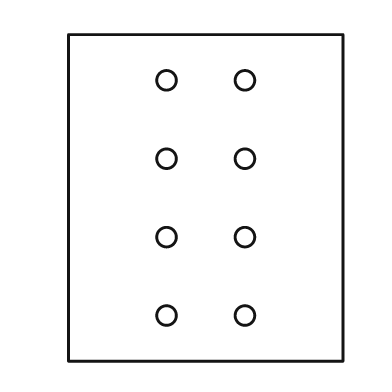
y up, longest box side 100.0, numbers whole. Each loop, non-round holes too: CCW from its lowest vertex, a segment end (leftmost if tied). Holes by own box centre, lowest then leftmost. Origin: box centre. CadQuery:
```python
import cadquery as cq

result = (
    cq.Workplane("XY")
    .moveTo(-42.0, -50.0)
    .lineTo(42.0, -50.0)
    .lineTo(42.0, 50.0)
    .lineTo(-42.0, 50.0)
    .close()
    .moveTo(-12.0, -36.0)
    .circle(3.0)
    .moveTo(12.0, -36.0)
    .circle(3.0)
    .moveTo(-12.0, -12.0)
    .circle(3.0)
    .moveTo(12.0, -12.0)
    .circle(3.0)
    .moveTo(-12.0, 12.0)
    .circle(3.0)
    .moveTo(12.0, 12.0)
    .circle(3.0)
    .moveTo(-12.0, 36.0)
    .circle(3.0)
    .moveTo(12.0, 36.0)
    .circle(3.0)
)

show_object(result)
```